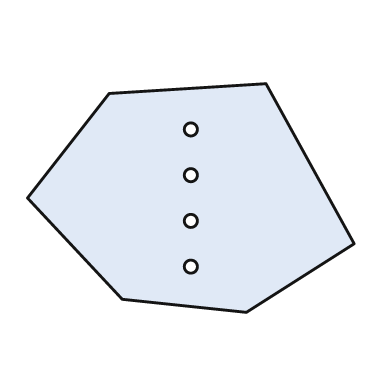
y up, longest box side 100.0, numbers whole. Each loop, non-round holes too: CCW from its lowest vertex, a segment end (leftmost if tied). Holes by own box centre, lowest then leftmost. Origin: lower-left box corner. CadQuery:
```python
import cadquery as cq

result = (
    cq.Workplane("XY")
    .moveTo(67.0, 0.0)
    .lineTo(100.0, 21.0)
    .lineTo(73.0, 70.0)
    .lineTo(25.0, 67.0)
    .lineTo(0.0, 35.0)
    .lineTo(29.0, 4.0)
    .close()
    .moveTo(50.0, 14.0)
    .circle(2.0)
    .moveTo(50.0, 28.0)
    .circle(2.0)
    .moveTo(50.0, 42.0)
    .circle(2.0)
    .moveTo(50.0, 56.0)
    .circle(2.0)
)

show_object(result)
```